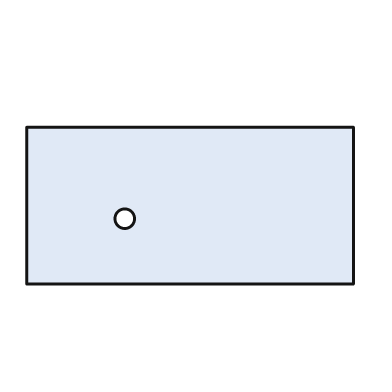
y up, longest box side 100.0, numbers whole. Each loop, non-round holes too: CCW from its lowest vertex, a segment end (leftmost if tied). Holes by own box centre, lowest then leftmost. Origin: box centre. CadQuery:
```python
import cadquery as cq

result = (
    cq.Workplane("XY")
    .moveTo(-50.0, -24.0)
    .lineTo(50.0, -24.0)
    .lineTo(50.0, 24.0)
    .lineTo(-50.0, 24.0)
    .close()
    .moveTo(-20.0, -4.0)
    .circle(3.0)
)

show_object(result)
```